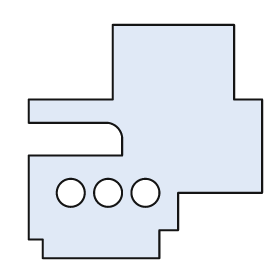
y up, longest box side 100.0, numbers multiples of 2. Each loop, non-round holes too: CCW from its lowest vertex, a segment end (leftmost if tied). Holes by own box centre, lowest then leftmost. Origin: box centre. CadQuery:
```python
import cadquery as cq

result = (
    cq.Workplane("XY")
    .moveTo(-44.0, -50.0)
    .lineTo(6.0, -50.0)
    .lineTo(6.0, -38.0)
    .lineTo(14.0, -38.0)
    .lineTo(14.0, -22.0)
    .lineTo(50.0, -22.0)
    .lineTo(50.0, 18.0)
    .lineTo(38.0, 18.0)
    .lineTo(38.0, 50.0)
    .lineTo(-14.0, 50.0)
    .lineTo(-14.0, 18.0)
    .lineTo(-50.0, 18.0)
    .lineTo(-50.0, 8.0)
    .lineTo(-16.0, 8.0)
    .threePointArc((-12.0, 6.0), (-10.0, 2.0))
    .lineTo(-10.0, -6.0)
    .lineTo(-50.0, -6.0)
    .lineTo(-50.0, -42.0)
    .lineTo(-44.0, -42.0)
    .close()
    .moveTo(-32.0, -22.0)
    .circle(6.0)
    .moveTo(-16.0, -22.0)
    .circle(6.0)
    .moveTo(0.0, -22.0)
    .circle(6.0)
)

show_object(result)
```